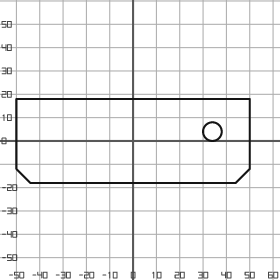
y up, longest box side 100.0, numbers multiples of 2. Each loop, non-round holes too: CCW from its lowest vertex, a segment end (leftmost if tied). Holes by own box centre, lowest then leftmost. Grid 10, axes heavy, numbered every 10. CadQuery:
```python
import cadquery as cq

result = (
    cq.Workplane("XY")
    .moveTo(-44.0, -18.0)
    .lineTo(44.0, -18.0)
    .lineTo(50.0, -12.0)
    .lineTo(50.0, 18.0)
    .lineTo(-50.0, 18.0)
    .lineTo(-50.0, -12.0)
    .close()
    .moveTo(34.0, 4.0)
    .circle(4.0)
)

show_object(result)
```